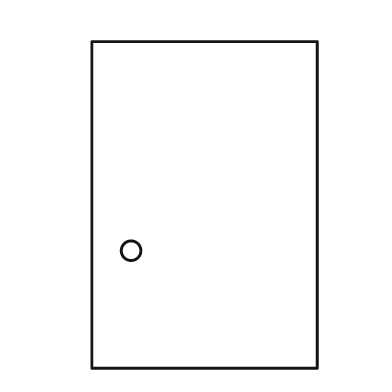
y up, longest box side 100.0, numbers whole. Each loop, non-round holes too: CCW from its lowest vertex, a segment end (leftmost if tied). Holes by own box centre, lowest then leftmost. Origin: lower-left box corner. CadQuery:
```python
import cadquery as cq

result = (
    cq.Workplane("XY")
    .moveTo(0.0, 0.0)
    .lineTo(69.0, 0.0)
    .lineTo(69.0, 100.0)
    .lineTo(0.0, 100.0)
    .close()
    .moveTo(12.0, 36.0)
    .circle(3.0)
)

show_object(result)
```